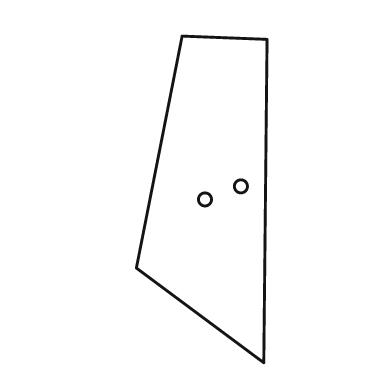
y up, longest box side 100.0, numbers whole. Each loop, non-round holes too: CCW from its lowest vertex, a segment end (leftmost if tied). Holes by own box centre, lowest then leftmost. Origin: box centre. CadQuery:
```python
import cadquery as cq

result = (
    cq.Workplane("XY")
    .moveTo(19.0, -50.0)
    .lineTo(20.0, 49.0)
    .lineTo(-6.0, 50.0)
    .lineTo(-20.0, -21.0)
    .close()
    .moveTo(1.0, 0.0)
    .circle(2.0)
    .moveTo(12.0, 4.0)
    .circle(2.0)
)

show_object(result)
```